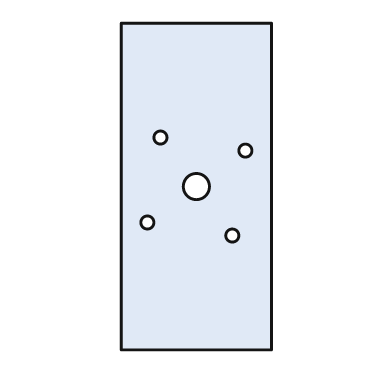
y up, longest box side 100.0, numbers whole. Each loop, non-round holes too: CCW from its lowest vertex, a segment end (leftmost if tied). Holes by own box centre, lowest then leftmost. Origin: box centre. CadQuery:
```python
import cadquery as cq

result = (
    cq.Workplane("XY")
    .moveTo(-23.0, -50.0)
    .lineTo(23.0, -50.0)
    .lineTo(23.0, 50.0)
    .lineTo(-23.0, 50.0)
    .close()
    .moveTo(11.0, -15.0)
    .circle(2.0)
    .moveTo(-15.0, -11.0)
    .circle(2.0)
    .moveTo(0.0, 0.0)
    .circle(4.0)
    .moveTo(15.0, 11.0)
    .circle(2.0)
    .moveTo(-11.0, 15.0)
    .circle(2.0)
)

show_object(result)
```